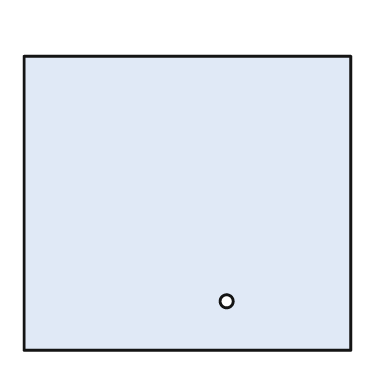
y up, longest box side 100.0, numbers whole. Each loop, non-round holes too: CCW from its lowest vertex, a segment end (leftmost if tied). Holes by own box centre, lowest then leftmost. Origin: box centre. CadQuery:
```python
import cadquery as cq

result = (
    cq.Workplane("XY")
    .moveTo(-50.0, -45.0)
    .lineTo(50.0, -45.0)
    .lineTo(50.0, 45.0)
    .lineTo(-50.0, 45.0)
    .close()
    .moveTo(12.0, -30.0)
    .circle(2.0)
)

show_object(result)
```